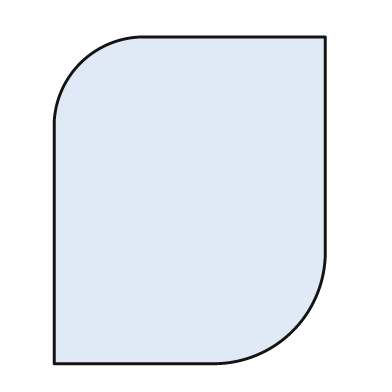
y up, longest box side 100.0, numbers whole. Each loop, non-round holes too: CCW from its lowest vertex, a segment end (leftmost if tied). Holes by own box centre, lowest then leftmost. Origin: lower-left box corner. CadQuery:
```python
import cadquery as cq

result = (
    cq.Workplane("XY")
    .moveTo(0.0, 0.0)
    .lineTo(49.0, 0.0)
    .threePointArc((73.0, 10.0), (83.0, 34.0))
    .lineTo(83.0, 100.0)
    .lineTo(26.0, 100.0)
    .threePointArc((8.0, 92.0), (0.0, 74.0))
    .close()
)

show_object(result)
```